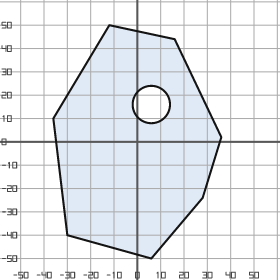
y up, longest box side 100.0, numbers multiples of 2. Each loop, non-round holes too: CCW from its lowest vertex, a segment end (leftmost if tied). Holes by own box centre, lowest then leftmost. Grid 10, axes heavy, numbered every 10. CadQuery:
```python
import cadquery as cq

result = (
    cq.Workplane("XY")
    .moveTo(6.0, -50.0)
    .lineTo(28.0, -24.0)
    .lineTo(36.0, 2.0)
    .lineTo(16.0, 44.0)
    .lineTo(-12.0, 50.0)
    .lineTo(-36.0, 10.0)
    .lineTo(-30.0, -40.0)
    .close()
    .moveTo(6.0, 16.0)
    .circle(8.0)
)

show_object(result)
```